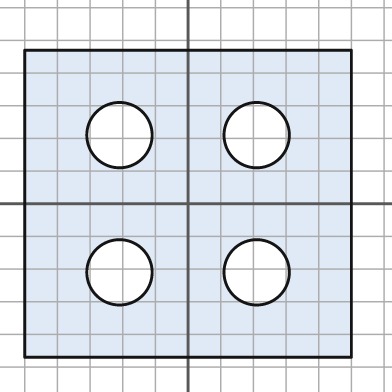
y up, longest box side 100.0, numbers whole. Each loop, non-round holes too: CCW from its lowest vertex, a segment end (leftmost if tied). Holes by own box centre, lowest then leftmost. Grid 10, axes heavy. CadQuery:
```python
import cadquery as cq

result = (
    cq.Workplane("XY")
    .moveTo(-50.0, -47.0)
    .lineTo(50.0, -47.0)
    .lineTo(50.0, 47.0)
    .lineTo(-50.0, 47.0)
    .close()
    .moveTo(-21.0, -21.0)
    .circle(10.0)
    .moveTo(21.0, -21.0)
    .circle(10.0)
    .moveTo(-21.0, 21.0)
    .circle(10.0)
    .moveTo(21.0, 21.0)
    .circle(10.0)
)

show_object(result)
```